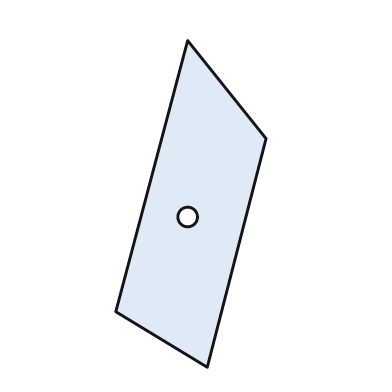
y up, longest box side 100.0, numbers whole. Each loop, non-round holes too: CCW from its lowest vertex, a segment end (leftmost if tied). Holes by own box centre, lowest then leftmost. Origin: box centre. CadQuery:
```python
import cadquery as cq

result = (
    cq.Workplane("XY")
    .moveTo(5.0, -50.0)
    .lineTo(23.0, 20.0)
    .lineTo(-1.0, 50.0)
    .lineTo(-23.0, -33.0)
    .close()
    .moveTo(-1.0, -4.0)
    .circle(3.0)
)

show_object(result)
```